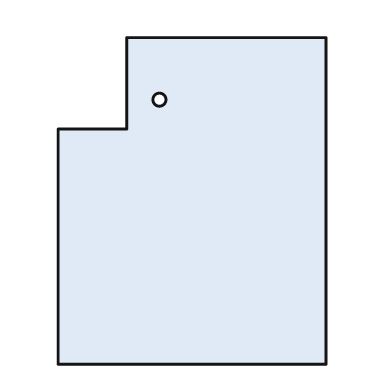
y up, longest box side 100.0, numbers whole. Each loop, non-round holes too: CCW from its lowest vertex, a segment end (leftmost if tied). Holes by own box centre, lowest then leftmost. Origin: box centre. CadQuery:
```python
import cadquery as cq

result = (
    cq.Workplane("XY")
    .moveTo(-41.0, -50.0)
    .lineTo(41.0, -50.0)
    .lineTo(41.0, 50.0)
    .lineTo(-20.0, 50.0)
    .lineTo(-20.0, 22.0)
    .lineTo(-41.0, 22.0)
    .close()
    .moveTo(-10.0, 31.0)
    .circle(2.0)
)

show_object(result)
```